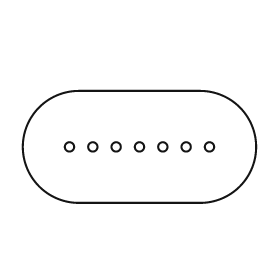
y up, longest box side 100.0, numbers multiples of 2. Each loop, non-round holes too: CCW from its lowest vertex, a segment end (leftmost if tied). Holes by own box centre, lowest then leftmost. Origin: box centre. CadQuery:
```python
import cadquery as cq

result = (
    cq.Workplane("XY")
    .moveTo(-26.0, -24.0)
    .lineTo(26.0, -24.0)
    .threePointArc((50.0, 0.0), (26.0, 24.0))
    .lineTo(-26.0, 24.0)
    .threePointArc((-50.0, 0.0), (-26.0, -24.0))
    .close()
    .moveTo(-30.0, 0.0)
    .circle(2.0)
    .moveTo(-20.0, 0.0)
    .circle(2.0)
    .moveTo(-10.0, 0.0)
    .circle(2.0)
    .moveTo(0.0, 0.0)
    .circle(2.0)
    .moveTo(10.0, 0.0)
    .circle(2.0)
    .moveTo(20.0, 0.0)
    .circle(2.0)
    .moveTo(30.0, 0.0)
    .circle(2.0)
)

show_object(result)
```